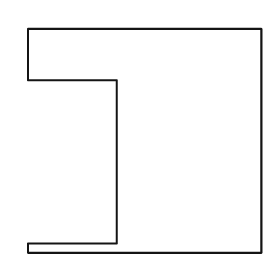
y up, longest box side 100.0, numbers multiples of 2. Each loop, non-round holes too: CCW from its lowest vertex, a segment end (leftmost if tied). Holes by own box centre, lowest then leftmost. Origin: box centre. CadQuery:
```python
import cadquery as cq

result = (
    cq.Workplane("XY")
    .moveTo(-50.0, -48.0)
    .lineTo(50.0, -48.0)
    .lineTo(50.0, 48.0)
    .lineTo(-50.0, 48.0)
    .lineTo(-50.0, 26.0)
    .lineTo(-12.0, 26.0)
    .lineTo(-12.0, -44.0)
    .lineTo(-50.0, -44.0)
    .close()
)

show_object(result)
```